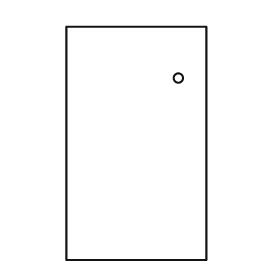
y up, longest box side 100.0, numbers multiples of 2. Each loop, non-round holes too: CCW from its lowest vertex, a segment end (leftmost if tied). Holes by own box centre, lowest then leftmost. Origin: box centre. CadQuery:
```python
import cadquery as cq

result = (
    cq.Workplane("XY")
    .moveTo(-30.0, -50.0)
    .lineTo(30.0, -50.0)
    .lineTo(30.0, 50.0)
    .lineTo(-30.0, 50.0)
    .close()
    .moveTo(18.0, 28.0)
    .circle(2.0)
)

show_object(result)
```